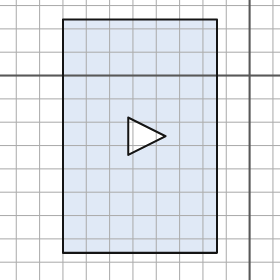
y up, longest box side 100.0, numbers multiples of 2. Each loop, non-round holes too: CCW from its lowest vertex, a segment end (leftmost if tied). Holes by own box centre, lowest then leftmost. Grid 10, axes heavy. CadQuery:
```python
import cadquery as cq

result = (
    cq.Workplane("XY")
    .moveTo(-80.0, -76.0)
    .lineTo(-14.0, -76.0)
    .lineTo(-14.0, 24.0)
    .lineTo(-80.0, 24.0)
    .close()
    .moveTo(-52.0, -34.0)
    .lineTo(-36.0, -26.0)
    .lineTo(-52.0, -18.0)
    .close()
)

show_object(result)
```